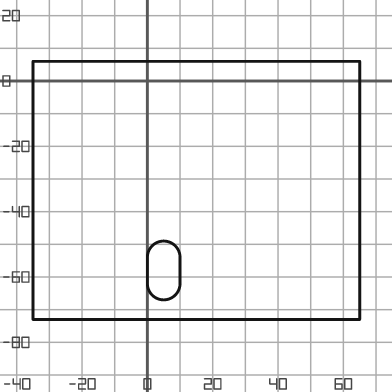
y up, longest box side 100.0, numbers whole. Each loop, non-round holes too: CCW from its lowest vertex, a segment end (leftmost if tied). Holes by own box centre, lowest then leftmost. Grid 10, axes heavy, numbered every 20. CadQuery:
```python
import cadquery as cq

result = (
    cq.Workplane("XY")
    .moveTo(-35.0, -73.0)
    .lineTo(65.0, -73.0)
    .lineTo(65.0, 6.0)
    .lineTo(-35.0, 6.0)
    .close()
    .moveTo(0.0, -62.0)
    .threePointArc((5.0, -67.0), (10.0, -62.0))
    .lineTo(10.0, -54.0)
    .threePointArc((5.0, -49.0), (0.0, -54.0))
    .close()
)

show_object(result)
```